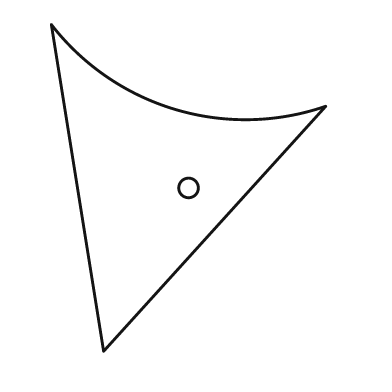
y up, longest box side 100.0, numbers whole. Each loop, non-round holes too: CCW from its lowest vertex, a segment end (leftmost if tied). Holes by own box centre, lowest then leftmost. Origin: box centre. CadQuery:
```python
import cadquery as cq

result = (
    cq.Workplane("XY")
    .moveTo(-26.0, -50.0)
    .lineTo(42.0, 25.0)
    .threePointArc((-4.0, 24.0), (-42.0, 50.0))
    .close()
    .moveTo(0.0, 0.0)
    .circle(3.0)
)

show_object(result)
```